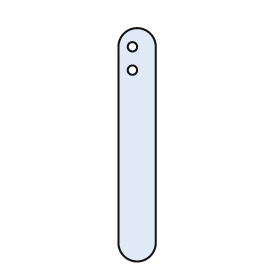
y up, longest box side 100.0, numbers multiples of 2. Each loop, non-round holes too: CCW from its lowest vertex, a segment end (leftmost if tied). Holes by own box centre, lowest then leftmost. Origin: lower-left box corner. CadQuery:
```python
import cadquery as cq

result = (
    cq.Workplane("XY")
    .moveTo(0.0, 8.0)
    .threePointArc((8.0, 0.0), (16.0, 8.0))
    .lineTo(16.0, 92.0)
    .threePointArc((8.0, 100.0), (0.0, 92.0))
    .close()
    .moveTo(6.0, 82.0)
    .circle(2.0)
    .moveTo(6.0, 92.0)
    .circle(2.0)
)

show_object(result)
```